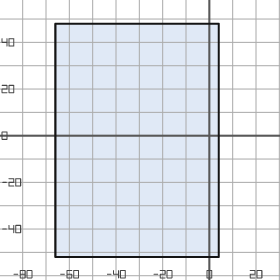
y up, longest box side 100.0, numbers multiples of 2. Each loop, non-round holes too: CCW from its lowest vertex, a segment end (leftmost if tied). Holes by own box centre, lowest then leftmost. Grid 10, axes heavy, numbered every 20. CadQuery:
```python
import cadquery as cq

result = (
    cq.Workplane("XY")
    .moveTo(-66.0, -52.0)
    .lineTo(4.0, -52.0)
    .lineTo(4.0, 48.0)
    .lineTo(-66.0, 48.0)
    .close()
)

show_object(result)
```